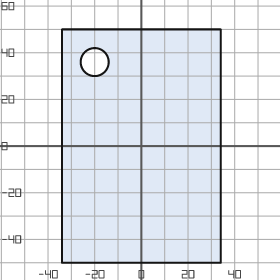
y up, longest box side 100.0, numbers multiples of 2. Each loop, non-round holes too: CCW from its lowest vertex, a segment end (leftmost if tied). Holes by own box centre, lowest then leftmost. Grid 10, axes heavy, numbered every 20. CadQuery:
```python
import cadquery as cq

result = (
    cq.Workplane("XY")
    .moveTo(-34.0, -50.0)
    .lineTo(34.0, -50.0)
    .lineTo(34.0, 50.0)
    .lineTo(-34.0, 50.0)
    .close()
    .moveTo(-20.0, 36.0)
    .circle(6.0)
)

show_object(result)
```